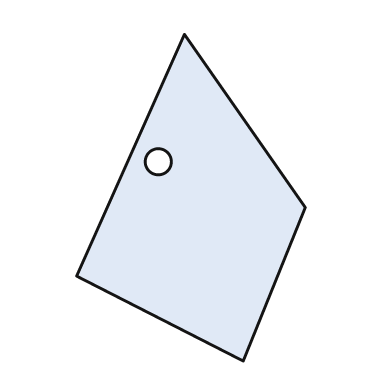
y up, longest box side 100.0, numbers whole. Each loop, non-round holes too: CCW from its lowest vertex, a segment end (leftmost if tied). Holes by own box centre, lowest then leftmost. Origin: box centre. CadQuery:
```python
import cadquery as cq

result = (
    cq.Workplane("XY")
    .moveTo(16.0, -50.0)
    .lineTo(35.0, -3.0)
    .lineTo(-2.0, 50.0)
    .lineTo(-35.0, -24.0)
    .close()
    .moveTo(-10.0, 11.0)
    .circle(4.0)
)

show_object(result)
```